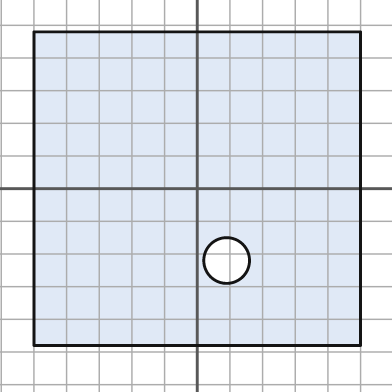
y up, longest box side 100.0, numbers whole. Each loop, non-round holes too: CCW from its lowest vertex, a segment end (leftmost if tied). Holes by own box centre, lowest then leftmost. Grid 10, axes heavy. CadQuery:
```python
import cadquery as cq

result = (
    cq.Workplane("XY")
    .moveTo(-50.0, -48.0)
    .lineTo(50.0, -48.0)
    .lineTo(50.0, 48.0)
    .lineTo(-50.0, 48.0)
    .close()
    .moveTo(9.0, -22.0)
    .circle(7.0)
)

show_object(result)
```